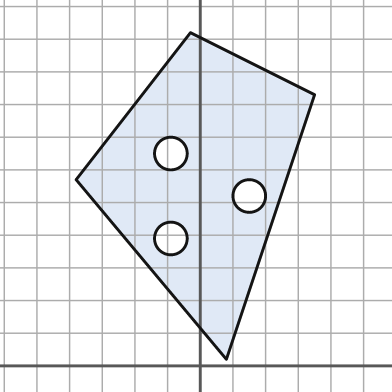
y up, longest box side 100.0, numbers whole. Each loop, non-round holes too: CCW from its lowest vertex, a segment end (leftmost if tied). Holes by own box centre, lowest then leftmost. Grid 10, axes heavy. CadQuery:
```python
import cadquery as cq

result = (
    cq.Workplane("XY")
    .moveTo(8.0, 2.0)
    .lineTo(35.0, 83.0)
    .lineTo(-3.0, 102.0)
    .lineTo(-38.0, 57.0)
    .close()
    .moveTo(-9.0, 39.0)
    .circle(5.0)
    .moveTo(15.0, 52.0)
    .circle(5.0)
    .moveTo(-9.0, 65.0)
    .circle(5.0)
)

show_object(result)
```